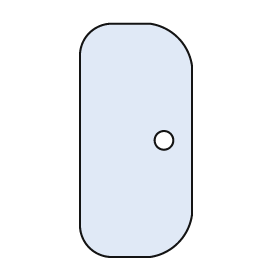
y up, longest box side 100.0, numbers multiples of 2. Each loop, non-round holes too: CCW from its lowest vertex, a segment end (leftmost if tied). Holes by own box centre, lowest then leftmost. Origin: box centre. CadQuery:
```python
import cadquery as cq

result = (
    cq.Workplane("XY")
    .moveTo(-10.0, -50.0)
    .lineTo(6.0, -50.0)
    .threePointArc((18.0, -44.0), (24.0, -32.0))
    .lineTo(24.0, 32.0)
    .threePointArc((18.0, 44.0), (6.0, 50.0))
    .lineTo(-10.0, 50.0)
    .threePointArc((-20.0, 46.0), (-24.0, 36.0))
    .lineTo(-24.0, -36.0)
    .threePointArc((-20.0, -46.0), (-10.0, -50.0))
    .close()
    .moveTo(12.0, 0.0)
    .circle(4.0)
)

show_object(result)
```